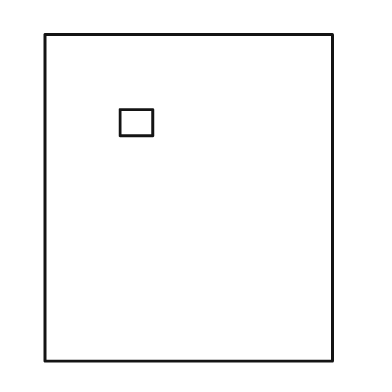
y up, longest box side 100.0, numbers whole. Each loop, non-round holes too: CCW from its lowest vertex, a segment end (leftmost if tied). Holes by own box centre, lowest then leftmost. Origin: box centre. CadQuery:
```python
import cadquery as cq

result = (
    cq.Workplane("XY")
    .moveTo(-44.0, -50.0)
    .lineTo(44.0, -50.0)
    .lineTo(44.0, 50.0)
    .lineTo(-44.0, 50.0)
    .close()
    .moveTo(-21.0, 19.0)
    .lineTo(-11.0, 19.0)
    .lineTo(-11.0, 27.0)
    .lineTo(-21.0, 27.0)
    .close()
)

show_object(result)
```